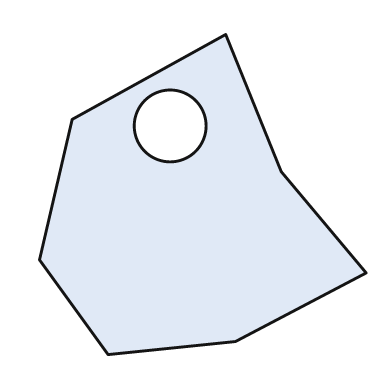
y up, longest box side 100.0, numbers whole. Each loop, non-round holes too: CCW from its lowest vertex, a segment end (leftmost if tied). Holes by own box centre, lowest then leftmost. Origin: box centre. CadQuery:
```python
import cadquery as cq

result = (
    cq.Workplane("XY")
    .moveTo(-29.0, -49.0)
    .lineTo(10.0, -45.0)
    .lineTo(50.0, -24.0)
    .lineTo(24.0, 7.0)
    .lineTo(7.0, 49.0)
    .lineTo(-40.0, 23.0)
    .lineTo(-50.0, -20.0)
    .close()
    .moveTo(-10.0, 21.0)
    .circle(11.0)
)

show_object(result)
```